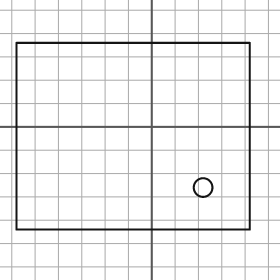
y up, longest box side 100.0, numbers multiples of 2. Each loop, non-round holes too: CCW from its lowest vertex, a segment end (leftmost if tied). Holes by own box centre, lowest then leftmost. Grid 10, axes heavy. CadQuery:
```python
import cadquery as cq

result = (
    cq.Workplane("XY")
    .moveTo(-58.0, -44.0)
    .lineTo(42.0, -44.0)
    .lineTo(42.0, 36.0)
    .lineTo(-58.0, 36.0)
    .close()
    .moveTo(22.0, -26.0)
    .circle(4.0)
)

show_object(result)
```